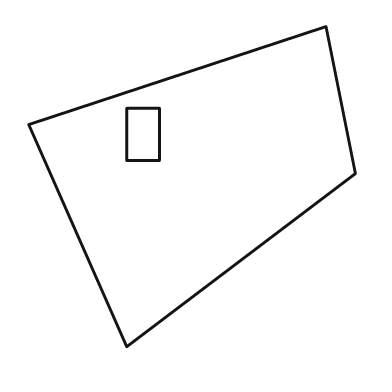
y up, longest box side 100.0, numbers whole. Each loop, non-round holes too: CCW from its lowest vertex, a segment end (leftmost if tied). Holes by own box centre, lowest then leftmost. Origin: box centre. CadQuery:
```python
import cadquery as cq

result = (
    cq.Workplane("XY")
    .moveTo(-20.0, -49.0)
    .lineTo(50.0, 4.0)
    .lineTo(41.0, 49.0)
    .lineTo(-50.0, 19.0)
    .close()
    .moveTo(-20.0, 8.0)
    .lineTo(-10.0, 8.0)
    .lineTo(-10.0, 24.0)
    .lineTo(-20.0, 24.0)
    .close()
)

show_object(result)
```